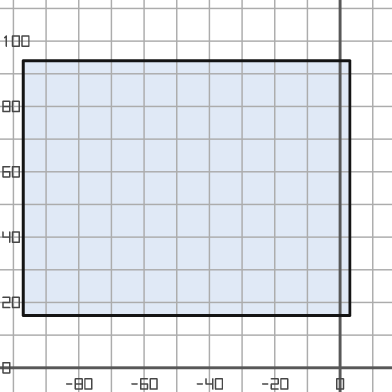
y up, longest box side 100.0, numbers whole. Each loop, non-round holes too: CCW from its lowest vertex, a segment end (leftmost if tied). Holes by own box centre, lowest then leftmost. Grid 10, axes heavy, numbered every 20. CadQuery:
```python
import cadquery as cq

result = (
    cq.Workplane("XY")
    .moveTo(-97.0, 16.0)
    .lineTo(3.0, 16.0)
    .lineTo(3.0, 94.0)
    .lineTo(-97.0, 94.0)
    .close()
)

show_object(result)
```